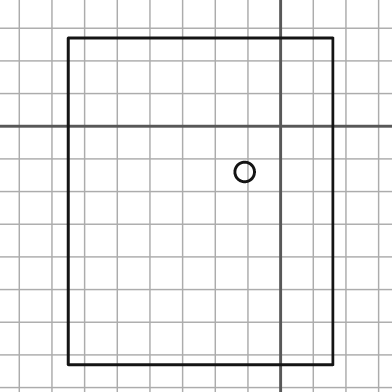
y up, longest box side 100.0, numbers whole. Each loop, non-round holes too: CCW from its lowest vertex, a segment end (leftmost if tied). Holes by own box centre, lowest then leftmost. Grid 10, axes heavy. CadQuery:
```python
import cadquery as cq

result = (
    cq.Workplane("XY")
    .moveTo(-65.0, -73.0)
    .lineTo(16.0, -73.0)
    .lineTo(16.0, 27.0)
    .lineTo(-65.0, 27.0)
    .close()
    .moveTo(-11.0, -14.0)
    .circle(3.0)
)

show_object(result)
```